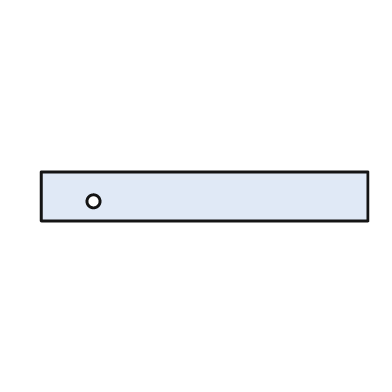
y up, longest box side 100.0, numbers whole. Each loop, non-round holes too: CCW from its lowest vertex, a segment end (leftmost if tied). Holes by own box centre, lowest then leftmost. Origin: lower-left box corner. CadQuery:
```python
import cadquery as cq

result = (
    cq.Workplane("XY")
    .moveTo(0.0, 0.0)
    .lineTo(100.0, 0.0)
    .lineTo(100.0, 15.0)
    .lineTo(0.0, 15.0)
    .close()
    .moveTo(16.0, 6.0)
    .circle(2.0)
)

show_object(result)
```